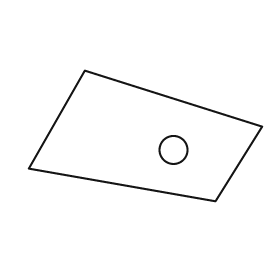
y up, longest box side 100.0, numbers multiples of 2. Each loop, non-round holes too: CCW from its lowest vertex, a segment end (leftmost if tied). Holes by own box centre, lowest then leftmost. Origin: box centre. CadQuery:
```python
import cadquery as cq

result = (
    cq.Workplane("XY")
    .moveTo(30.0, -28.0)
    .lineTo(50.0, 4.0)
    .lineTo(-26.0, 28.0)
    .lineTo(-50.0, -14.0)
    .close()
    .moveTo(12.0, -6.0)
    .circle(6.0)
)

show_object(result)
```